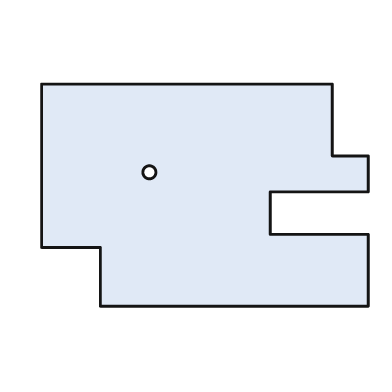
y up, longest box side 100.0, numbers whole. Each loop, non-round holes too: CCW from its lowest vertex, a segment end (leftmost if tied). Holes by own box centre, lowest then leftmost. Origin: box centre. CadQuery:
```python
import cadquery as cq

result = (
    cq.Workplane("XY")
    .moveTo(-32.0, -34.0)
    .lineTo(50.0, -34.0)
    .lineTo(50.0, -12.0)
    .lineTo(20.0, -12.0)
    .lineTo(20.0, 1.0)
    .lineTo(50.0, 1.0)
    .lineTo(50.0, 12.0)
    .lineTo(39.0, 12.0)
    .lineTo(39.0, 34.0)
    .lineTo(-50.0, 34.0)
    .lineTo(-50.0, -16.0)
    .lineTo(-32.0, -16.0)
    .close()
    .moveTo(-17.0, 7.0)
    .circle(2.0)
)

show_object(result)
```